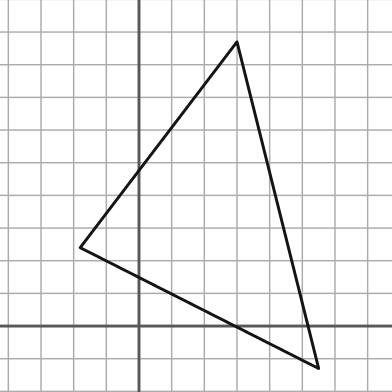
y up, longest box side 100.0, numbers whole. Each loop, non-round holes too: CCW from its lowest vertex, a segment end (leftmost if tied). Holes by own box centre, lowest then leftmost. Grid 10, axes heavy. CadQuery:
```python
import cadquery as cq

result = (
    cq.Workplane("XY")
    .moveTo(55.0, -13.0)
    .lineTo(30.0, 87.0)
    .lineTo(-18.0, 24.0)
    .close()
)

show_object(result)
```